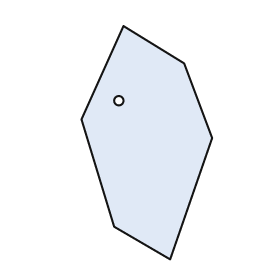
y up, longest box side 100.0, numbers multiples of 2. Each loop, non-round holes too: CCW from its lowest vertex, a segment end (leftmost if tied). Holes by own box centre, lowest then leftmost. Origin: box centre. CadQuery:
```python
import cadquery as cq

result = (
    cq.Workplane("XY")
    .moveTo(10.0, -50.0)
    .lineTo(28.0, 2.0)
    .lineTo(16.0, 34.0)
    .lineTo(-10.0, 50.0)
    .lineTo(-28.0, 10.0)
    .lineTo(-14.0, -36.0)
    .close()
    .moveTo(-12.0, 18.0)
    .circle(2.0)
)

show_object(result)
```